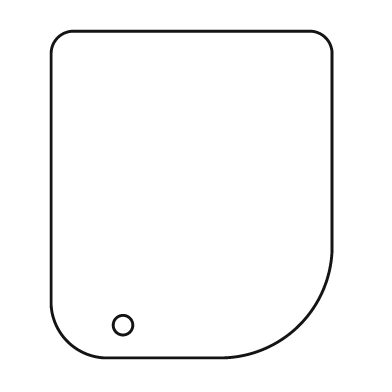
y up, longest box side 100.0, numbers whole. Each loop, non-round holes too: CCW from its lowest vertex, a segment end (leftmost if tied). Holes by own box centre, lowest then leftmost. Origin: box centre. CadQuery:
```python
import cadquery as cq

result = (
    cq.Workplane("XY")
    .moveTo(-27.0, -50.0)
    .lineTo(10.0, -50.0)
    .threePointArc((33.0, -40.0), (43.0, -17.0))
    .lineTo(43.0, 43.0)
    .threePointArc((41.0, 48.0), (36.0, 50.0))
    .lineTo(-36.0, 50.0)
    .threePointArc((-41.0, 48.0), (-43.0, 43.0))
    .lineTo(-43.0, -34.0)
    .threePointArc((-38.0, -45.0), (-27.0, -50.0))
    .close()
    .moveTo(-21.0, -40.0)
    .circle(3.0)
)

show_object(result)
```